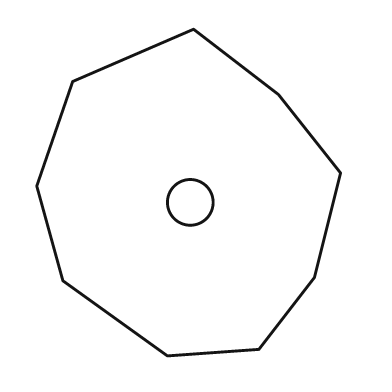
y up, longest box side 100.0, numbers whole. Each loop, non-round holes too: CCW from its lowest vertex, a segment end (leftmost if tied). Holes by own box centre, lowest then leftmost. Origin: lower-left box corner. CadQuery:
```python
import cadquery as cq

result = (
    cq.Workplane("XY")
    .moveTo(40.0, 0.0)
    .lineTo(68.0, 2.0)
    .lineTo(85.0, 24.0)
    .lineTo(93.0, 56.0)
    .lineTo(74.0, 80.0)
    .lineTo(48.0, 100.0)
    .lineTo(11.0, 84.0)
    .lineTo(0.0, 52.0)
    .lineTo(8.0, 23.0)
    .close()
    .moveTo(47.0, 47.0)
    .circle(7.0)
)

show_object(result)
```